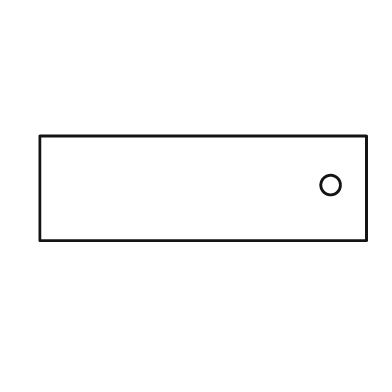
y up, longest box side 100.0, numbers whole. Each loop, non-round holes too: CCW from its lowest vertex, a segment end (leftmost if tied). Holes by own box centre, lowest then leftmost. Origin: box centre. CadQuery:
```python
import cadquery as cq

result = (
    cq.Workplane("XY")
    .moveTo(-50.0, -16.0)
    .lineTo(50.0, -16.0)
    .lineTo(50.0, 16.0)
    .lineTo(-50.0, 16.0)
    .close()
    .moveTo(39.0, 1.0)
    .circle(3.0)
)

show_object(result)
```